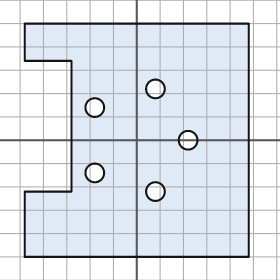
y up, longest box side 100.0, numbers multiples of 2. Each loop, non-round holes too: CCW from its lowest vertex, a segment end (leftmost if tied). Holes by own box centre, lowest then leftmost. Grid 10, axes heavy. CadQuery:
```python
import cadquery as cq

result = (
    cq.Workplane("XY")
    .moveTo(-48.0, -50.0)
    .lineTo(48.0, -50.0)
    .lineTo(48.0, 50.0)
    .lineTo(-48.0, 50.0)
    .lineTo(-48.0, 34.0)
    .lineTo(-28.0, 34.0)
    .lineTo(-28.0, -22.0)
    .lineTo(-48.0, -22.0)
    .close()
    .moveTo(8.0, -22.0)
    .circle(4.0)
    .moveTo(-18.0, -14.0)
    .circle(4.0)
    .moveTo(22.0, 0.0)
    .circle(4.0)
    .moveTo(-18.0, 14.0)
    .circle(4.0)
    .moveTo(8.0, 22.0)
    .circle(4.0)
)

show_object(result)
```